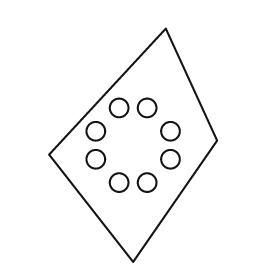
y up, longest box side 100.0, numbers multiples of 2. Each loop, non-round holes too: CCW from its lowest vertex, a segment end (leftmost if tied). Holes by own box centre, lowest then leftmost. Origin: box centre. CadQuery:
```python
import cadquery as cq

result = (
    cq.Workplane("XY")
    .moveTo(0.0, -50.0)
    .lineTo(36.0, 2.0)
    .lineTo(14.0, 50.0)
    .lineTo(-36.0, -4.0)
    .close()
    .moveTo(-6.0, -16.0)
    .circle(4.0)
    .moveTo(6.0, -16.0)
    .circle(4.0)
    .moveTo(-16.0, -6.0)
    .circle(4.0)
    .moveTo(16.0, -6.0)
    .circle(4.0)
    .moveTo(-16.0, 6.0)
    .circle(4.0)
    .moveTo(16.0, 6.0)
    .circle(4.0)
    .moveTo(-6.0, 16.0)
    .circle(4.0)
    .moveTo(6.0, 16.0)
    .circle(4.0)
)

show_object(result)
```